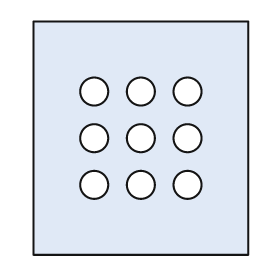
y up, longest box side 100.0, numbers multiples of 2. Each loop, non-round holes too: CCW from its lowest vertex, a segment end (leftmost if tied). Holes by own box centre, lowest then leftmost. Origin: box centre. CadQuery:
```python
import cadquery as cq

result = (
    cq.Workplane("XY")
    .moveTo(-46.0, -50.0)
    .lineTo(46.0, -50.0)
    .lineTo(46.0, 50.0)
    .lineTo(-46.0, 50.0)
    .close()
    .moveTo(-20.0, -20.0)
    .circle(6.0)
    .moveTo(0.0, -20.0)
    .circle(6.0)
    .moveTo(20.0, -20.0)
    .circle(6.0)
    .moveTo(-20.0, 0.0)
    .circle(6.0)
    .moveTo(0.0, 0.0)
    .circle(6.0)
    .moveTo(20.0, 0.0)
    .circle(6.0)
    .moveTo(-20.0, 20.0)
    .circle(6.0)
    .moveTo(0.0, 20.0)
    .circle(6.0)
    .moveTo(20.0, 20.0)
    .circle(6.0)
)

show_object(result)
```